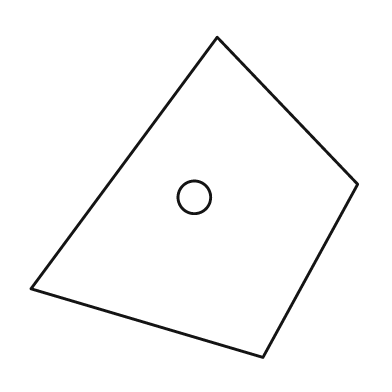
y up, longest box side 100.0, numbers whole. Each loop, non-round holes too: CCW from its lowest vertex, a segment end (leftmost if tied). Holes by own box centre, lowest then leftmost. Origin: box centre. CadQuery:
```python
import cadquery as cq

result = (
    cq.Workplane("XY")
    .moveTo(21.0, -49.0)
    .lineTo(50.0, 4.0)
    .lineTo(7.0, 49.0)
    .lineTo(-50.0, -28.0)
    .close()
    .moveTo(0.0, 0.0)
    .circle(5.0)
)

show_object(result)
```